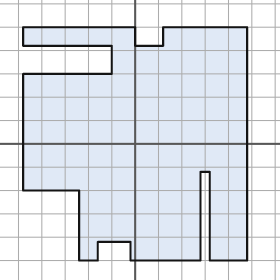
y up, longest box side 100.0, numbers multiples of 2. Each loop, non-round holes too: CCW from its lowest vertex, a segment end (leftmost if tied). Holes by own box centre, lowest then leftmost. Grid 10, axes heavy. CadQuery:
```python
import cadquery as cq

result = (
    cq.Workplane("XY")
    .moveTo(-24.0, -50.0)
    .lineTo(-16.0, -50.0)
    .lineTo(-16.0, -42.0)
    .lineTo(-2.0, -42.0)
    .lineTo(-2.0, -50.0)
    .lineTo(28.0, -50.0)
    .lineTo(28.0, -12.0)
    .lineTo(32.0, -12.0)
    .lineTo(32.0, -50.0)
    .lineTo(48.0, -50.0)
    .lineTo(48.0, 50.0)
    .lineTo(12.0, 50.0)
    .lineTo(12.0, 42.0)
    .lineTo(0.0, 42.0)
    .lineTo(0.0, 50.0)
    .lineTo(-48.0, 50.0)
    .lineTo(-48.0, 42.0)
    .lineTo(-10.0, 42.0)
    .lineTo(-10.0, 30.0)
    .lineTo(-48.0, 30.0)
    .lineTo(-48.0, -20.0)
    .lineTo(-24.0, -20.0)
    .close()
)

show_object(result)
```